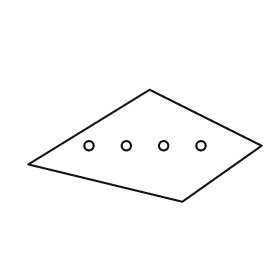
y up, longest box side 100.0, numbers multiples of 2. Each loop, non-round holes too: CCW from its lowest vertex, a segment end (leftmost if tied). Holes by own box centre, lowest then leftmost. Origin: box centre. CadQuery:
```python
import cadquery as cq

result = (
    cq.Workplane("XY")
    .moveTo(16.0, -24.0)
    .lineTo(50.0, 0.0)
    .lineTo(2.0, 24.0)
    .lineTo(-50.0, -8.0)
    .close()
    .moveTo(-24.0, 0.0)
    .circle(2.0)
    .moveTo(-8.0, 0.0)
    .circle(2.0)
    .moveTo(8.0, 0.0)
    .circle(2.0)
    .moveTo(24.0, 0.0)
    .circle(2.0)
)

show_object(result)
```